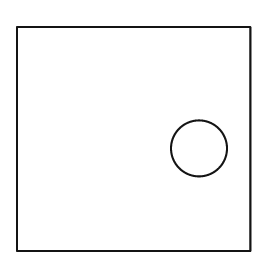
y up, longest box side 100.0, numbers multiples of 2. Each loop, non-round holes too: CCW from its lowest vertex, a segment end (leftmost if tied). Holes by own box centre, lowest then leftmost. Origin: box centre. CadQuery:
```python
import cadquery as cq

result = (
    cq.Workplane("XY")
    .moveTo(-50.0, -48.0)
    .lineTo(50.0, -48.0)
    .lineTo(50.0, 48.0)
    .lineTo(-50.0, 48.0)
    .close()
    .moveTo(28.0, -4.0)
    .circle(12.0)
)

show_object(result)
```